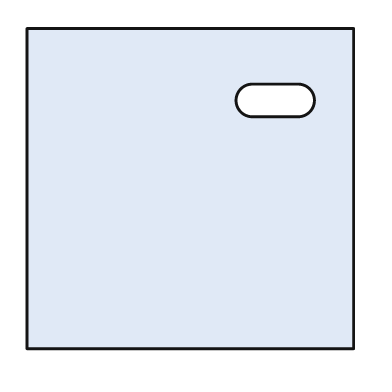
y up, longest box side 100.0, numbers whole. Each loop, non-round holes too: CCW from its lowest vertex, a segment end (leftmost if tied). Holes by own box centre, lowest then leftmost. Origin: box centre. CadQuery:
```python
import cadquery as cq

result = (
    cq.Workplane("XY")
    .moveTo(-50.0, -49.0)
    .lineTo(50.0, -49.0)
    .lineTo(50.0, 49.0)
    .lineTo(-50.0, 49.0)
    .close()
    .moveTo(19.0, 22.0)
    .lineTo(33.0, 22.0)
    .threePointArc((38.0, 27.0), (33.0, 32.0))
    .lineTo(19.0, 32.0)
    .threePointArc((14.0, 27.0), (19.0, 22.0))
    .close()
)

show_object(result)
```